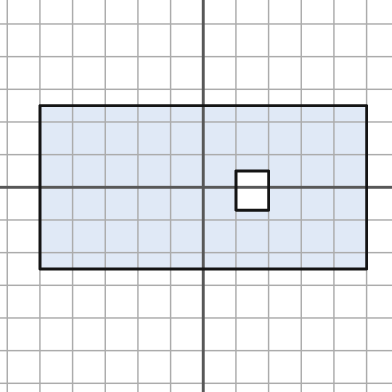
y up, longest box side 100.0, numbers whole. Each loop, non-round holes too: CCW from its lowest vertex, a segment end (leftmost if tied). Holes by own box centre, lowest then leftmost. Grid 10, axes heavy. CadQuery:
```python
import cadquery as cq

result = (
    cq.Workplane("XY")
    .moveTo(-50.0, -25.0)
    .lineTo(50.0, -25.0)
    .lineTo(50.0, 25.0)
    .lineTo(-50.0, 25.0)
    .close()
    .moveTo(10.0, -7.0)
    .lineTo(20.0, -7.0)
    .lineTo(20.0, 5.0)
    .lineTo(10.0, 5.0)
    .close()
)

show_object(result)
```